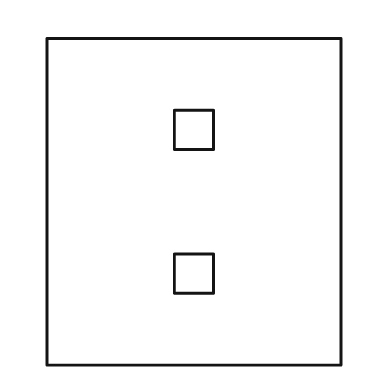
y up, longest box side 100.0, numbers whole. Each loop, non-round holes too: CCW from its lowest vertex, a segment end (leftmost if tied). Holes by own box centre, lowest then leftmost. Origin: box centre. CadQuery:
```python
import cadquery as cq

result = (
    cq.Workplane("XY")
    .moveTo(-45.0, -50.0)
    .lineTo(45.0, -50.0)
    .lineTo(45.0, 50.0)
    .lineTo(-45.0, 50.0)
    .close()
    .moveTo(-6.0, -28.0)
    .lineTo(6.0, -28.0)
    .lineTo(6.0, -16.0)
    .lineTo(-6.0, -16.0)
    .close()
    .moveTo(-6.0, 16.0)
    .lineTo(6.0, 16.0)
    .lineTo(6.0, 28.0)
    .lineTo(-6.0, 28.0)
    .close()
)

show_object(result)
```